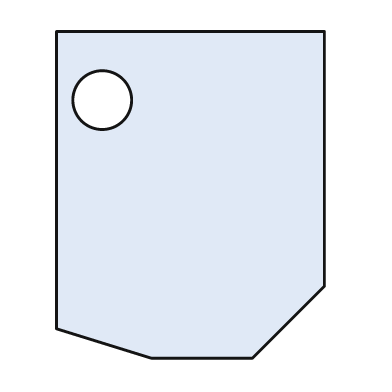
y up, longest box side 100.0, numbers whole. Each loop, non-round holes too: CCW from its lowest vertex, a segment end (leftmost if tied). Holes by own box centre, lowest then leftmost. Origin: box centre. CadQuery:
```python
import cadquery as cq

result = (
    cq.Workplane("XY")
    .moveTo(-12.0, -50.0)
    .lineTo(19.0, -50.0)
    .lineTo(41.0, -28.0)
    .lineTo(41.0, 50.0)
    .lineTo(-41.0, 50.0)
    .lineTo(-41.0, -41.0)
    .close()
    .moveTo(-27.0, 29.0)
    .circle(9.0)
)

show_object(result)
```